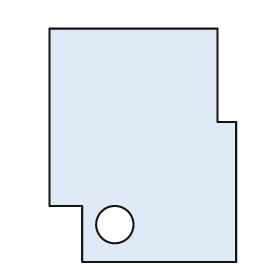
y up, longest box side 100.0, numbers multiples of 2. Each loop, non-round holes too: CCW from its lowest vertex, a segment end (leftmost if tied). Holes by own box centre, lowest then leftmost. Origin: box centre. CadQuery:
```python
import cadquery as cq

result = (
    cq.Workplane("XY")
    .moveTo(-26.0, -50.0)
    .lineTo(40.0, -50.0)
    .lineTo(40.0, 10.0)
    .lineTo(32.0, 10.0)
    .lineTo(32.0, 50.0)
    .lineTo(-40.0, 50.0)
    .lineTo(-40.0, -26.0)
    .lineTo(-26.0, -26.0)
    .close()
    .moveTo(-12.0, -34.0)
    .circle(8.0)
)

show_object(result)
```